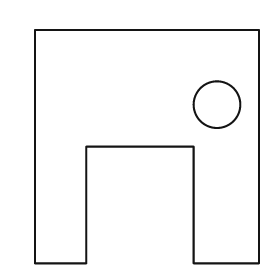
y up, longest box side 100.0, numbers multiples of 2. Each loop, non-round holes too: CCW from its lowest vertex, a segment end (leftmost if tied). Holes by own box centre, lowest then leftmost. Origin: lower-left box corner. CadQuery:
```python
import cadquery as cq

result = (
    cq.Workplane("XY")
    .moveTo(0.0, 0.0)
    .lineTo(22.0, 0.0)
    .lineTo(22.0, 50.0)
    .lineTo(68.0, 50.0)
    .lineTo(68.0, 0.0)
    .lineTo(96.0, 0.0)
    .lineTo(96.0, 100.0)
    .lineTo(0.0, 100.0)
    .close()
    .moveTo(78.0, 68.0)
    .circle(10.0)
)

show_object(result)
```